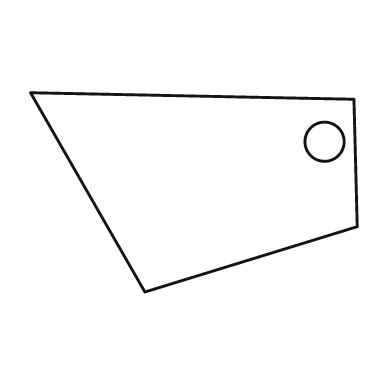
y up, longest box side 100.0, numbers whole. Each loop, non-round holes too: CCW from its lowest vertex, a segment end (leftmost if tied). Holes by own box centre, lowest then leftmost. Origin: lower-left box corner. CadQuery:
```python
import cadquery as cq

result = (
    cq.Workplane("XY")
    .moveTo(35.0, 0.0)
    .lineTo(100.0, 20.0)
    .lineTo(99.0, 59.0)
    .lineTo(0.0, 61.0)
    .close()
    .moveTo(90.0, 46.0)
    .circle(6.0)
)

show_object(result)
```